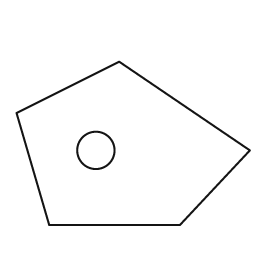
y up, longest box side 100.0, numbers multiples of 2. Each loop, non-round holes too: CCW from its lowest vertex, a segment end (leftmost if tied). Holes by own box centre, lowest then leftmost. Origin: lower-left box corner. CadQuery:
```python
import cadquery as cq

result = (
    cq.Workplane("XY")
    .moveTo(14.0, 0.0)
    .lineTo(70.0, 0.0)
    .lineTo(100.0, 32.0)
    .lineTo(44.0, 70.0)
    .lineTo(0.0, 48.0)
    .close()
    .moveTo(34.0, 32.0)
    .circle(8.0)
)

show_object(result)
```